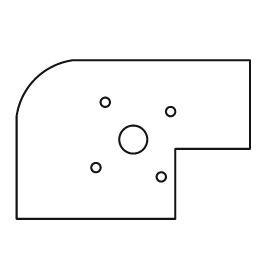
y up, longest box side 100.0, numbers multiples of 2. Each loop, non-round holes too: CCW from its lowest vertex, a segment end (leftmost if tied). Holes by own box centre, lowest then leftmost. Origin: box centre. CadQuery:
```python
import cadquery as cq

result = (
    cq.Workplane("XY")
    .moveTo(-50.0, -34.0)
    .lineTo(18.0, -34.0)
    .lineTo(18.0, -4.0)
    .lineTo(50.0, -4.0)
    .lineTo(50.0, 34.0)
    .lineTo(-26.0, 34.0)
    .threePointArc((-42.0, 26.0), (-50.0, 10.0))
    .close()
    .moveTo(12.0, -16.0)
    .circle(2.0)
    .moveTo(-16.0, -12.0)
    .circle(2.0)
    .moveTo(0.0, 0.0)
    .circle(6.0)
    .moveTo(16.0, 12.0)
    .circle(2.0)
    .moveTo(-12.0, 16.0)
    .circle(2.0)
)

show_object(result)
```